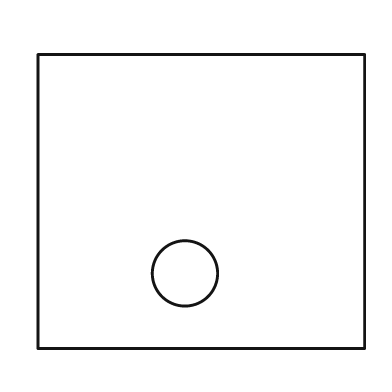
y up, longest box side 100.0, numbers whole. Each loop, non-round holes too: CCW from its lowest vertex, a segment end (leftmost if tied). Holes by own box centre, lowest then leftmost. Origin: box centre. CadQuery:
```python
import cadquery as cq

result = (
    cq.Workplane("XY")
    .moveTo(-50.0, -45.0)
    .lineTo(50.0, -45.0)
    .lineTo(50.0, 45.0)
    .lineTo(-50.0, 45.0)
    .close()
    .moveTo(-5.0, -22.0)
    .circle(10.0)
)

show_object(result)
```